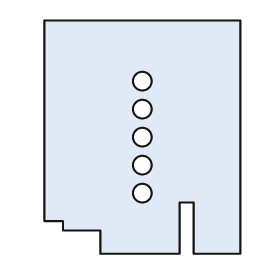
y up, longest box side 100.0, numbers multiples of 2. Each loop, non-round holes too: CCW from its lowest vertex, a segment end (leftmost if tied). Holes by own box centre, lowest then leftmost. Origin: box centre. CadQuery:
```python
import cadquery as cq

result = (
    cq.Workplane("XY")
    .moveTo(-18.0, -50.0)
    .lineTo(16.0, -50.0)
    .lineTo(16.0, -28.0)
    .lineTo(22.0, -28.0)
    .lineTo(22.0, -50.0)
    .lineTo(42.0, -50.0)
    .lineTo(42.0, 50.0)
    .lineTo(-42.0, 50.0)
    .lineTo(-42.0, -36.0)
    .lineTo(-34.0, -36.0)
    .lineTo(-34.0, -40.0)
    .lineTo(-18.0, -40.0)
    .close()
    .moveTo(0.0, -24.0)
    .circle(4.0)
    .moveTo(0.0, -12.0)
    .circle(4.0)
    .moveTo(0.0, 0.0)
    .circle(4.0)
    .moveTo(0.0, 12.0)
    .circle(4.0)
    .moveTo(0.0, 24.0)
    .circle(4.0)
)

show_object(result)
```